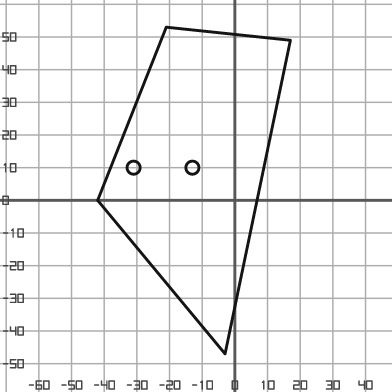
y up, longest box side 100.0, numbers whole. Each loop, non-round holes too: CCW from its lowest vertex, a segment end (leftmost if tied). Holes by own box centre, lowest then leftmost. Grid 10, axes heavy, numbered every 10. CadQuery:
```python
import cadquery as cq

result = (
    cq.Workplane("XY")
    .moveTo(-3.0, -47.0)
    .lineTo(17.0, 49.0)
    .lineTo(-21.0, 53.0)
    .lineTo(-42.0, 0.0)
    .close()
    .moveTo(-31.0, 10.0)
    .circle(2.0)
    .moveTo(-13.0, 10.0)
    .circle(2.0)
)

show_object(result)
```